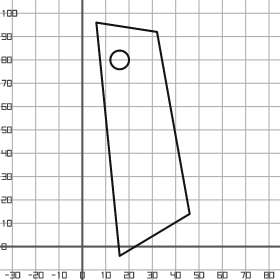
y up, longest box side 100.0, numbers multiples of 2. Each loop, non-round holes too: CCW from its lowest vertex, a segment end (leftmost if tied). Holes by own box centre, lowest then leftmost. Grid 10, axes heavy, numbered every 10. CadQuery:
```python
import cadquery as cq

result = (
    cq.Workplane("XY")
    .moveTo(16.0, -4.0)
    .lineTo(46.0, 14.0)
    .lineTo(32.0, 92.0)
    .lineTo(6.0, 96.0)
    .close()
    .moveTo(16.0, 80.0)
    .circle(4.0)
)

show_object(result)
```